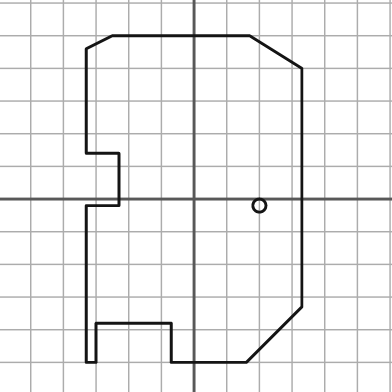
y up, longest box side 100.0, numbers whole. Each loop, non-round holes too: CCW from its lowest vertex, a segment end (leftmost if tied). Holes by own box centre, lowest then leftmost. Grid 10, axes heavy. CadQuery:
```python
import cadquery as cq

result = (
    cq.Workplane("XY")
    .moveTo(-33.0, -50.0)
    .lineTo(-30.0, -50.0)
    .lineTo(-30.0, -38.0)
    .lineTo(-7.0, -38.0)
    .lineTo(-7.0, -50.0)
    .lineTo(16.0, -50.0)
    .lineTo(33.0, -33.0)
    .lineTo(33.0, 40.0)
    .lineTo(17.0, 50.0)
    .lineTo(-25.0, 50.0)
    .lineTo(-33.0, 46.0)
    .lineTo(-33.0, 14.0)
    .lineTo(-23.0, 14.0)
    .lineTo(-23.0, -2.0)
    .lineTo(-33.0, -2.0)
    .close()
    .moveTo(20.0, -2.0)
    .circle(2.0)
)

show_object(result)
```